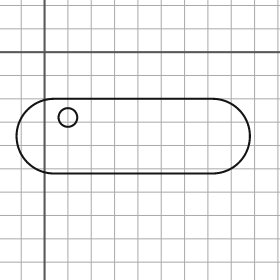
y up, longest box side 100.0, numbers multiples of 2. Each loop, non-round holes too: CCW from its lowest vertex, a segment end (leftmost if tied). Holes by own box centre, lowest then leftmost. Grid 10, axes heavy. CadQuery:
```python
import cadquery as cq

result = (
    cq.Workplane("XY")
    .moveTo(4.0, -52.0)
    .lineTo(72.0, -52.0)
    .threePointArc((88.0, -36.0), (72.0, -20.0))
    .lineTo(4.0, -20.0)
    .threePointArc((-12.0, -36.0), (4.0, -52.0))
    .close()
    .moveTo(10.0, -28.0)
    .circle(4.0)
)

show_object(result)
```